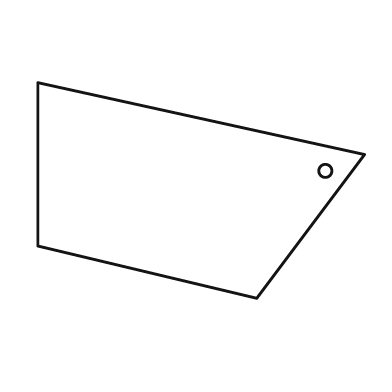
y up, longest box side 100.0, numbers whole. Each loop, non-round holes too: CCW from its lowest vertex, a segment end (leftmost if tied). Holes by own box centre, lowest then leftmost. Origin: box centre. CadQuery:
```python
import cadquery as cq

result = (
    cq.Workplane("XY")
    .moveTo(17.0, -33.0)
    .lineTo(50.0, 11.0)
    .lineTo(-50.0, 33.0)
    .lineTo(-50.0, -17.0)
    .close()
    .moveTo(38.0, 6.0)
    .circle(2.0)
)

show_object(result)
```